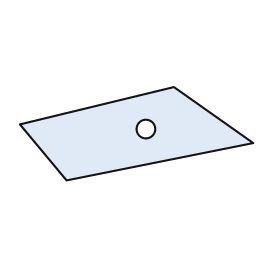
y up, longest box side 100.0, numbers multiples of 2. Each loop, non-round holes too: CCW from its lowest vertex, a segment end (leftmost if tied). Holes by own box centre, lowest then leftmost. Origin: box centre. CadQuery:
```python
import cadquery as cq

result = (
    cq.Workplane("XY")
    .moveTo(-30.0, -20.0)
    .lineTo(50.0, -4.0)
    .lineTo(16.0, 20.0)
    .lineTo(-50.0, 4.0)
    .close()
    .moveTo(4.0, 2.0)
    .circle(4.0)
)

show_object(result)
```